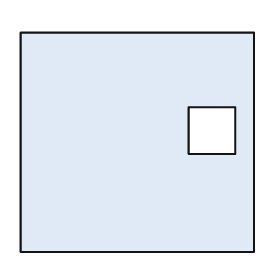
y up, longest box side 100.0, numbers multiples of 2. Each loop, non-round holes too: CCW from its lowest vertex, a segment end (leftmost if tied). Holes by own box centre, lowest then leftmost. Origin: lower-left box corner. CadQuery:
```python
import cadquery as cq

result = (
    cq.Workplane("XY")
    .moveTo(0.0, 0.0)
    .lineTo(100.0, 0.0)
    .lineTo(100.0, 94.0)
    .lineTo(0.0, 94.0)
    .close()
    .moveTo(72.0, 42.0)
    .lineTo(92.0, 42.0)
    .lineTo(92.0, 62.0)
    .lineTo(72.0, 62.0)
    .close()
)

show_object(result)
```